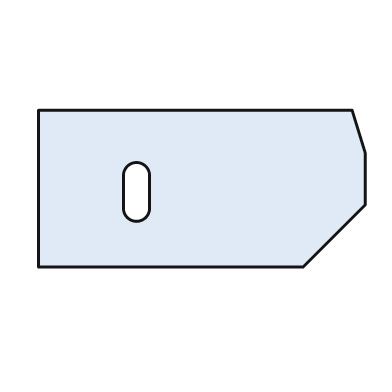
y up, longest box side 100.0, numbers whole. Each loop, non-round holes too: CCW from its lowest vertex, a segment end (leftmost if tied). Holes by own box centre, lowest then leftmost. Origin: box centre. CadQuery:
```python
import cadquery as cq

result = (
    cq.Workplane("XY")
    .moveTo(-50.0, -24.0)
    .lineTo(31.0, -24.0)
    .lineTo(50.0, -5.0)
    .lineTo(50.0, 11.0)
    .lineTo(46.0, 24.0)
    .lineTo(-50.0, 24.0)
    .close()
    .moveTo(-24.0, -6.0)
    .threePointArc((-20.0, -10.0), (-16.0, -6.0))
    .lineTo(-16.0, 4.0)
    .threePointArc((-20.0, 8.0), (-24.0, 4.0))
    .close()
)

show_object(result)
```